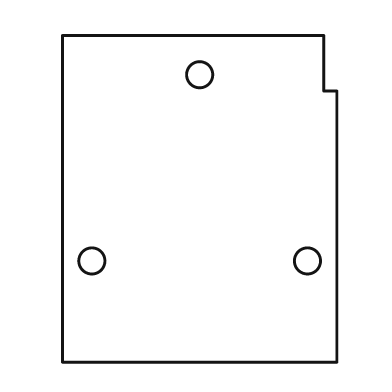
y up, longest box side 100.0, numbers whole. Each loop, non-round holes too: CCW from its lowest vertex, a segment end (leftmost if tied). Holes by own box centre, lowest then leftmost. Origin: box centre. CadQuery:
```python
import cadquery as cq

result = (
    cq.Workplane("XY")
    .moveTo(-42.0, -50.0)
    .lineTo(42.0, -50.0)
    .lineTo(42.0, 33.0)
    .lineTo(38.0, 33.0)
    .lineTo(38.0, 50.0)
    .lineTo(-42.0, 50.0)
    .close()
    .moveTo(-33.0, -19.0)
    .circle(4.0)
    .moveTo(33.0, -19.0)
    .circle(4.0)
    .moveTo(0.0, 38.0)
    .circle(4.0)
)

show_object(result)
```